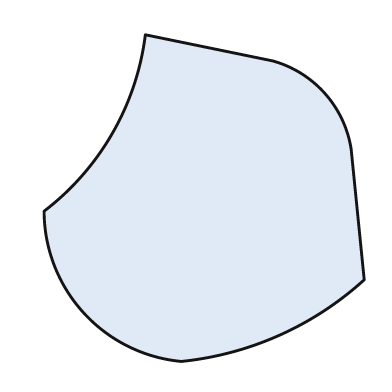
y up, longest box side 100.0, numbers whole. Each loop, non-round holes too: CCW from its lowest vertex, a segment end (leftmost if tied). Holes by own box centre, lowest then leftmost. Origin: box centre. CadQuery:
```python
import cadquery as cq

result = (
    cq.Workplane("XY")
    .moveTo(-7.0, -50.0)
    .threePointArc((23.0, -42.0), (49.0, -25.0))
    .lineTo(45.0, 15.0)
    .threePointArc((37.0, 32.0), (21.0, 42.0))
    .lineTo(-18.0, 50.0)
    .threePointArc((-28.0, 20.0), (-49.0, -4.0))
    .threePointArc((-37.0, -35.0), (-7.0, -50.0))
    .close()
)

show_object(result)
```